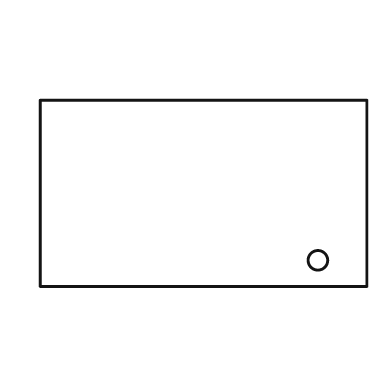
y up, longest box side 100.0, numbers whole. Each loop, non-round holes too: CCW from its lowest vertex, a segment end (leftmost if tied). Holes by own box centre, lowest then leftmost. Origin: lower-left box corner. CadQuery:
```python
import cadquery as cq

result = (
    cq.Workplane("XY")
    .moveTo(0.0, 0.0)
    .lineTo(100.0, 0.0)
    .lineTo(100.0, 57.0)
    .lineTo(0.0, 57.0)
    .close()
    .moveTo(85.0, 8.0)
    .circle(3.0)
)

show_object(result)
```